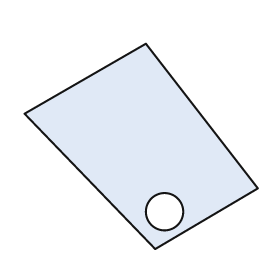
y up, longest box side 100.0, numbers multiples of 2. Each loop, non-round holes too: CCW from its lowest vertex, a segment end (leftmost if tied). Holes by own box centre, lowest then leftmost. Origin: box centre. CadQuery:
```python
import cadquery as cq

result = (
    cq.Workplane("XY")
    .moveTo(6.0, -44.0)
    .lineTo(50.0, -18.0)
    .lineTo(2.0, 44.0)
    .lineTo(-50.0, 14.0)
    .close()
    .moveTo(10.0, -28.0)
    .circle(8.0)
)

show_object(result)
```